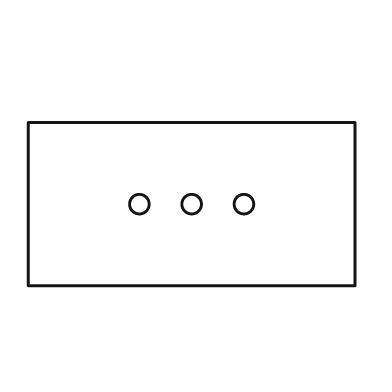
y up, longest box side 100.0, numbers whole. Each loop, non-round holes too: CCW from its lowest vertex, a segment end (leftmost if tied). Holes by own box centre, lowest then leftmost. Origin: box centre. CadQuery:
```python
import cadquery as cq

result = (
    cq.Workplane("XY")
    .moveTo(-50.0, -25.0)
    .lineTo(50.0, -25.0)
    .lineTo(50.0, 25.0)
    .lineTo(-50.0, 25.0)
    .close()
    .moveTo(-16.0, 0.0)
    .circle(3.0)
    .moveTo(0.0, 0.0)
    .circle(3.0)
    .moveTo(16.0, 0.0)
    .circle(3.0)
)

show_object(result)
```